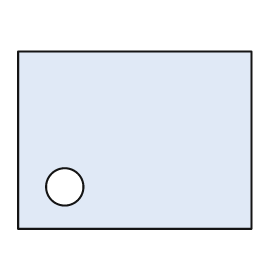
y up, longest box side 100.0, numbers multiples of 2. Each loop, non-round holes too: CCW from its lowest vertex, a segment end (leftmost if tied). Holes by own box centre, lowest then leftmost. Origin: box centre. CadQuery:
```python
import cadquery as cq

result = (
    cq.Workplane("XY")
    .moveTo(-50.0, -38.0)
    .lineTo(50.0, -38.0)
    .lineTo(50.0, 38.0)
    .lineTo(-50.0, 38.0)
    .close()
    .moveTo(-30.0, -20.0)
    .circle(8.0)
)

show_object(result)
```